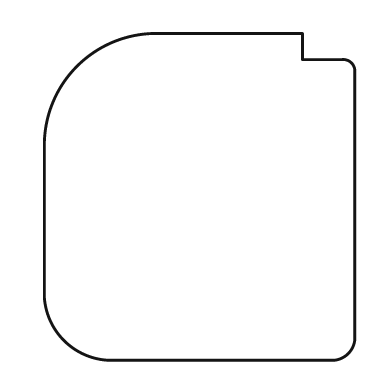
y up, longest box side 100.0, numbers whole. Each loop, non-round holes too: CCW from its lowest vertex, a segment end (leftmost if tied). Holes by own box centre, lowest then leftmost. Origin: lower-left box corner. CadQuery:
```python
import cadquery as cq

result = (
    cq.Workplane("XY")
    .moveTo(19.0, 0.0)
    .lineTo(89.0, 0.0)
    .threePointArc((93.0, 2.0), (95.0, 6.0))
    .lineTo(95.0, 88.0)
    .threePointArc((94.0, 91.0), (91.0, 92.0))
    .lineTo(79.0, 92.0)
    .lineTo(79.0, 100.0)
    .lineTo(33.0, 100.0)
    .threePointArc((10.0, 90.0), (0.0, 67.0))
    .lineTo(0.0, 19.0)
    .threePointArc((6.0, 6.0), (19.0, 0.0))
    .close()
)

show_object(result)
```